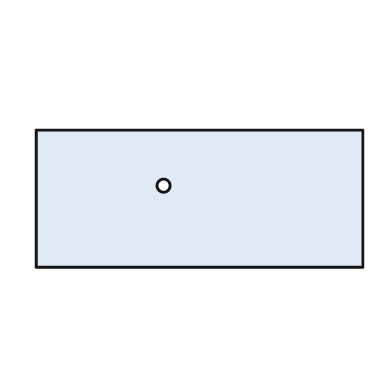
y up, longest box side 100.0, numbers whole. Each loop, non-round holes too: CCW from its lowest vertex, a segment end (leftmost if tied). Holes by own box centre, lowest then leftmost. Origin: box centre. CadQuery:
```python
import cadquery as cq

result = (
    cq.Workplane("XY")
    .moveTo(-50.0, -21.0)
    .lineTo(50.0, -21.0)
    .lineTo(50.0, 21.0)
    .lineTo(-50.0, 21.0)
    .close()
    .moveTo(-11.0, 4.0)
    .circle(2.0)
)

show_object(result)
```